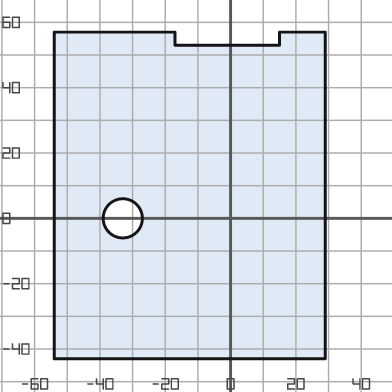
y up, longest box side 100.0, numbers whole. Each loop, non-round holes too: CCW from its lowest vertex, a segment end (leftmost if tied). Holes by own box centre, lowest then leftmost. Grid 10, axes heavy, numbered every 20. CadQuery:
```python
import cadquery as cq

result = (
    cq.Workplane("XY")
    .moveTo(-54.0, -43.0)
    .lineTo(29.0, -43.0)
    .lineTo(29.0, 57.0)
    .lineTo(15.0, 57.0)
    .lineTo(15.0, 53.0)
    .lineTo(-17.0, 53.0)
    .lineTo(-17.0, 57.0)
    .lineTo(-54.0, 57.0)
    .close()
    .moveTo(-33.0, 0.0)
    .circle(6.0)
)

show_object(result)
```